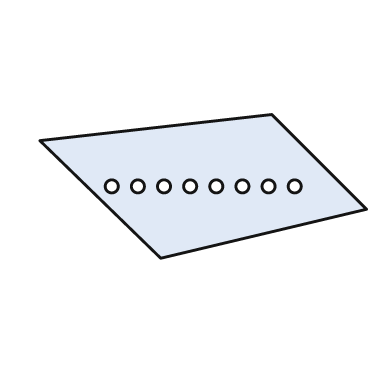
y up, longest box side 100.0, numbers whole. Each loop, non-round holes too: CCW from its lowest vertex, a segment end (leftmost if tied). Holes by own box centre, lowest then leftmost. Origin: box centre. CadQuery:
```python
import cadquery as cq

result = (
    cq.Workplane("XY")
    .moveTo(-13.0, -22.0)
    .lineTo(50.0, -7.0)
    .lineTo(21.0, 22.0)
    .lineTo(-50.0, 14.0)
    .close()
    .moveTo(-28.0, 0.0)
    .circle(2.0)
    .moveTo(-20.0, 0.0)
    .circle(2.0)
    .moveTo(-12.0, 0.0)
    .circle(2.0)
    .moveTo(-4.0, 0.0)
    .circle(2.0)
    .moveTo(4.0, 0.0)
    .circle(2.0)
    .moveTo(12.0, 0.0)
    .circle(2.0)
    .moveTo(20.0, 0.0)
    .circle(2.0)
    .moveTo(28.0, 0.0)
    .circle(2.0)
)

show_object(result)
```